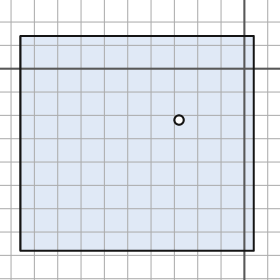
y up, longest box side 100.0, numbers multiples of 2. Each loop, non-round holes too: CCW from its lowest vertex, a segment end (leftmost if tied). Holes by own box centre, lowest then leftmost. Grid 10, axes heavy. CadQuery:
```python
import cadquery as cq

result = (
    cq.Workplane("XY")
    .moveTo(-96.0, -78.0)
    .lineTo(4.0, -78.0)
    .lineTo(4.0, 14.0)
    .lineTo(-96.0, 14.0)
    .close()
    .moveTo(-28.0, -22.0)
    .circle(2.0)
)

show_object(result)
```